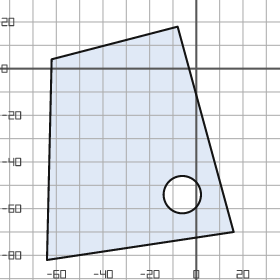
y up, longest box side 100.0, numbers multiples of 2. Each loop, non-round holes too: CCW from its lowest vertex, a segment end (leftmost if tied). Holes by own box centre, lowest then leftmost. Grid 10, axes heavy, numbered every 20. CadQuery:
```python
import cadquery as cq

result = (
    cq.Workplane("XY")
    .moveTo(-64.0, -82.0)
    .lineTo(16.0, -70.0)
    .lineTo(-8.0, 18.0)
    .lineTo(-62.0, 4.0)
    .close()
    .moveTo(-6.0, -54.0)
    .circle(8.0)
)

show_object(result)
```